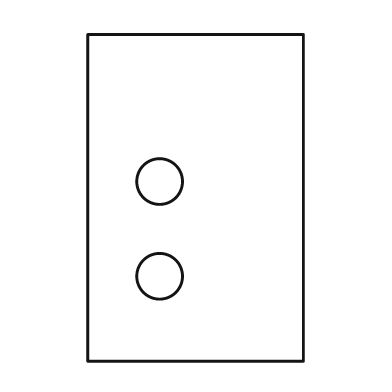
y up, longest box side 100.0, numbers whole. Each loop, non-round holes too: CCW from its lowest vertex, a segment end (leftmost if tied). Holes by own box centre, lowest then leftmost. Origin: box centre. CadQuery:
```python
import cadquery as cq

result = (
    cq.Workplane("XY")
    .moveTo(-33.0, -50.0)
    .lineTo(33.0, -50.0)
    .lineTo(33.0, 50.0)
    .lineTo(-33.0, 50.0)
    .close()
    .moveTo(-11.0, -24.0)
    .circle(7.0)
    .moveTo(-11.0, 5.0)
    .circle(7.0)
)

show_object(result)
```